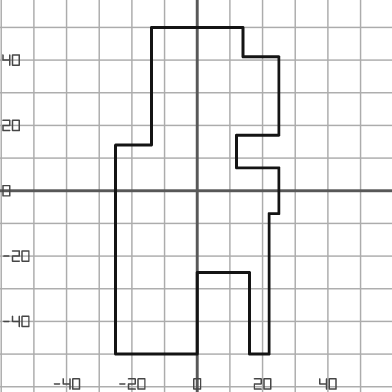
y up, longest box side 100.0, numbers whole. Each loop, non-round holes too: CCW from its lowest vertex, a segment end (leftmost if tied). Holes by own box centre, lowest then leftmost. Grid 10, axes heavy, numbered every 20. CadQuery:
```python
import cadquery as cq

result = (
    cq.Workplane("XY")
    .moveTo(-25.0, -50.0)
    .lineTo(0.0, -50.0)
    .lineTo(0.0, -25.0)
    .lineTo(16.0, -25.0)
    .lineTo(16.0, -50.0)
    .lineTo(22.0, -50.0)
    .lineTo(22.0, -7.0)
    .lineTo(25.0, -7.0)
    .lineTo(25.0, 7.0)
    .lineTo(12.0, 7.0)
    .lineTo(12.0, 17.0)
    .lineTo(25.0, 17.0)
    .lineTo(25.0, 41.0)
    .lineTo(14.0, 41.0)
    .lineTo(14.0, 50.0)
    .lineTo(-14.0, 50.0)
    .lineTo(-14.0, 14.0)
    .lineTo(-25.0, 14.0)
    .close()
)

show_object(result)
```